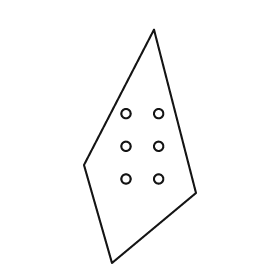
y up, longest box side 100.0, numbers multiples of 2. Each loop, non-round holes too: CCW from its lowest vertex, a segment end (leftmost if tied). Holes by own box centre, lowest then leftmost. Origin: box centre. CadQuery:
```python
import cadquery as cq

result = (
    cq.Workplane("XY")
    .moveTo(-12.0, -50.0)
    .lineTo(24.0, -20.0)
    .lineTo(6.0, 50.0)
    .lineTo(-24.0, -8.0)
    .close()
    .moveTo(-6.0, -14.0)
    .circle(2.0)
    .moveTo(8.0, -14.0)
    .circle(2.0)
    .moveTo(-6.0, 0.0)
    .circle(2.0)
    .moveTo(8.0, 0.0)
    .circle(2.0)
    .moveTo(-6.0, 14.0)
    .circle(2.0)
    .moveTo(8.0, 14.0)
    .circle(2.0)
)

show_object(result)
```